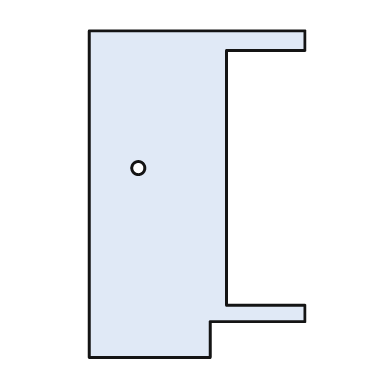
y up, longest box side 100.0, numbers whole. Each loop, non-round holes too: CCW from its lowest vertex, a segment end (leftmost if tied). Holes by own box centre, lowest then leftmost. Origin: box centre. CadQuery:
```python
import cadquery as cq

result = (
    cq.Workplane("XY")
    .moveTo(-33.0, -50.0)
    .lineTo(4.0, -50.0)
    .lineTo(4.0, -39.0)
    .lineTo(33.0, -39.0)
    .lineTo(33.0, -34.0)
    .lineTo(9.0, -34.0)
    .lineTo(9.0, 44.0)
    .lineTo(33.0, 44.0)
    .lineTo(33.0, 50.0)
    .lineTo(-33.0, 50.0)
    .close()
    .moveTo(-18.0, 8.0)
    .circle(2.0)
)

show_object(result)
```